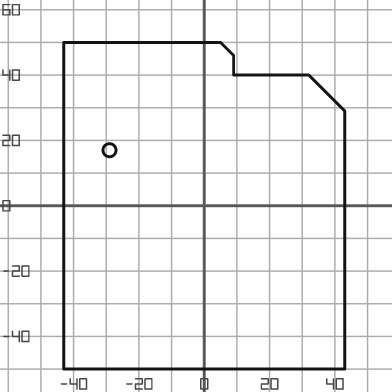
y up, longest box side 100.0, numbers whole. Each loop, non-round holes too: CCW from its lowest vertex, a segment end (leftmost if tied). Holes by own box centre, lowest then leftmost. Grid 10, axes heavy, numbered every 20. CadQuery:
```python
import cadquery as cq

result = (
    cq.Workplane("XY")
    .moveTo(-43.0, -50.0)
    .lineTo(43.0, -50.0)
    .lineTo(43.0, 29.0)
    .lineTo(32.0, 40.0)
    .lineTo(9.0, 40.0)
    .lineTo(9.0, 46.0)
    .lineTo(5.0, 50.0)
    .lineTo(-43.0, 50.0)
    .close()
    .moveTo(-29.0, 17.0)
    .circle(2.0)
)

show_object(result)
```